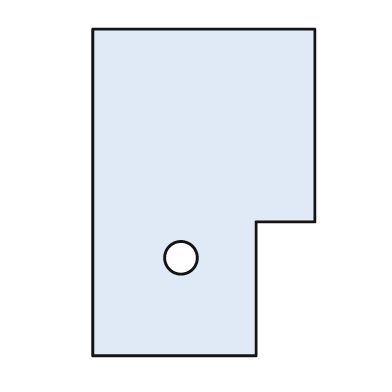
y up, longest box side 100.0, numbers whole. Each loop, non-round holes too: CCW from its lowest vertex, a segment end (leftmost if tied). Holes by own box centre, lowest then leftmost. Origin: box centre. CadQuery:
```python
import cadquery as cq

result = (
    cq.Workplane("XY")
    .moveTo(-34.0, -50.0)
    .lineTo(16.0, -50.0)
    .lineTo(16.0, -9.0)
    .lineTo(34.0, -9.0)
    .lineTo(34.0, 50.0)
    .lineTo(-34.0, 50.0)
    .close()
    .moveTo(-7.0, -20.0)
    .circle(5.0)
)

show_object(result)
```